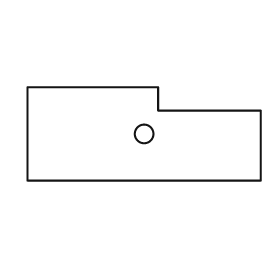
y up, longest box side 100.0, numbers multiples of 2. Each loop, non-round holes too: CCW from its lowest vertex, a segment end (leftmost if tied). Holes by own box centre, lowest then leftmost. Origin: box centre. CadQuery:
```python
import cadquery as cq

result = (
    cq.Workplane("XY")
    .moveTo(-50.0, -20.0)
    .lineTo(50.0, -20.0)
    .lineTo(50.0, 10.0)
    .lineTo(6.0, 10.0)
    .lineTo(6.0, 20.0)
    .lineTo(-50.0, 20.0)
    .close()
    .moveTo(0.0, 0.0)
    .circle(4.0)
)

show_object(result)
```